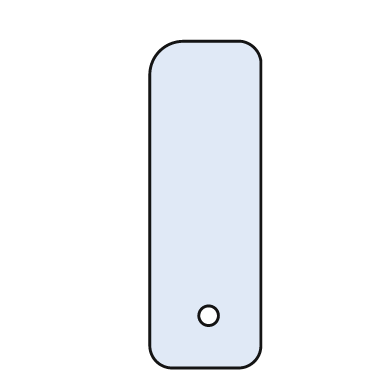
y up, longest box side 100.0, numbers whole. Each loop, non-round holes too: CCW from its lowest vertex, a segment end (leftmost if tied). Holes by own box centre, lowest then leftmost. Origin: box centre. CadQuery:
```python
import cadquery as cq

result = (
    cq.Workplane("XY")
    .moveTo(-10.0, -50.0)
    .lineTo(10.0, -50.0)
    .threePointArc((15.0, -48.0), (17.0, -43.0))
    .lineTo(17.0, 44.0)
    .threePointArc((15.0, 48.0), (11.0, 50.0))
    .lineTo(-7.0, 50.0)
    .threePointArc((-14.0, 47.0), (-17.0, 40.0))
    .lineTo(-17.0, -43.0)
    .threePointArc((-15.0, -48.0), (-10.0, -50.0))
    .close()
    .moveTo(1.0, -34.0)
    .circle(3.0)
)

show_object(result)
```